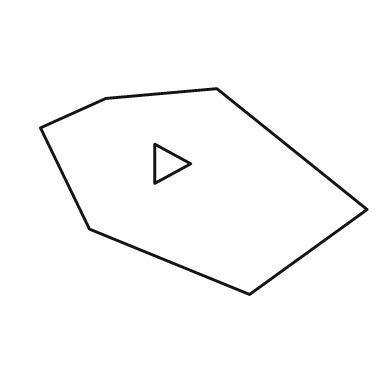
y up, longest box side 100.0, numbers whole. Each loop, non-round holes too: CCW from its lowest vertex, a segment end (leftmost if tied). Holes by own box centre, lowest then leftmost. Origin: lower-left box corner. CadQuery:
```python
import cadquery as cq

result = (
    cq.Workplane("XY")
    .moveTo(64.0, 0.0)
    .lineTo(100.0, 26.0)
    .lineTo(54.0, 63.0)
    .lineTo(20.0, 60.0)
    .lineTo(0.0, 51.0)
    .lineTo(15.0, 20.0)
    .close()
    .moveTo(35.0, 34.0)
    .lineTo(46.0, 40.0)
    .lineTo(35.0, 46.0)
    .close()
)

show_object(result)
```